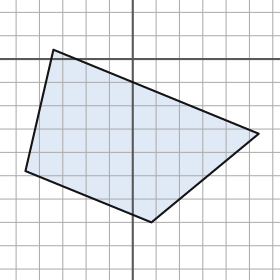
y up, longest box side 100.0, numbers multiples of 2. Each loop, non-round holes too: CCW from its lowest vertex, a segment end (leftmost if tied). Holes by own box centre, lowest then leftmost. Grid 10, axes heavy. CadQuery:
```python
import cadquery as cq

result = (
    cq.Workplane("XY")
    .moveTo(8.0, -70.0)
    .lineTo(54.0, -32.0)
    .lineTo(-34.0, 4.0)
    .lineTo(-46.0, -48.0)
    .close()
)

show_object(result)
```